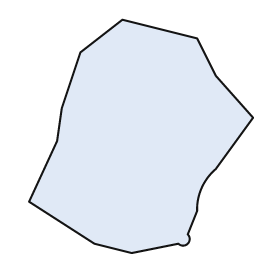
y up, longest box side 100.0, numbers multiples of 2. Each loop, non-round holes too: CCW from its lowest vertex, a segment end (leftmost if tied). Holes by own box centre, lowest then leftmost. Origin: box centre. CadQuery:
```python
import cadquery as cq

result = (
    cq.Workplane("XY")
    .moveTo(-4.0, -50.0)
    .lineTo(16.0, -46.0)
    .threePointArc((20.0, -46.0), (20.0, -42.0))
    .lineTo(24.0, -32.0)
    .threePointArc((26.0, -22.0), (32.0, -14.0))
    .lineTo(48.0, 8.0)
    .lineTo(32.0, 26.0)
    .lineTo(24.0, 42.0)
    .lineTo(-8.0, 50.0)
    .lineTo(-26.0, 36.0)
    .lineTo(-34.0, 12.0)
    .lineTo(-36.0, -2.0)
    .lineTo(-48.0, -28.0)
    .lineTo(-20.0, -46.0)
    .close()
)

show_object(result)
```